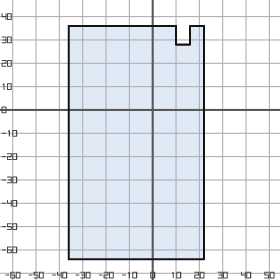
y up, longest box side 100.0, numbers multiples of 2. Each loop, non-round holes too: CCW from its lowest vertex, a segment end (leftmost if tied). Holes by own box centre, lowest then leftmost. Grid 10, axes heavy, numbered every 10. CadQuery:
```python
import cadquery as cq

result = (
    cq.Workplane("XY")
    .moveTo(-36.0, -64.0)
    .lineTo(22.0, -64.0)
    .lineTo(22.0, 36.0)
    .lineTo(16.0, 36.0)
    .lineTo(16.0, 28.0)
    .lineTo(10.0, 28.0)
    .lineTo(10.0, 36.0)
    .lineTo(-36.0, 36.0)
    .close()
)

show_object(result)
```